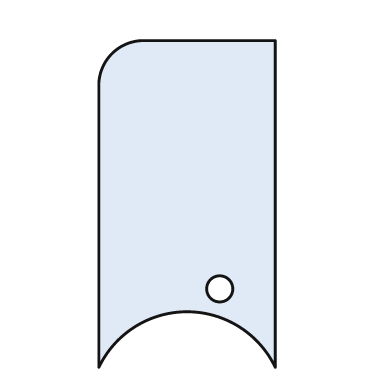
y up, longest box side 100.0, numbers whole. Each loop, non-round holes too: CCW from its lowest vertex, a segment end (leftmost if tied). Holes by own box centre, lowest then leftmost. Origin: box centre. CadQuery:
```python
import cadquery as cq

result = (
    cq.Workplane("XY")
    .moveTo(-27.0, -50.0)
    .threePointArc((0.0, -33.0), (27.0, -50.0))
    .lineTo(27.0, 50.0)
    .lineTo(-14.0, 50.0)
    .threePointArc((-23.0, 46.0), (-27.0, 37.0))
    .close()
    .moveTo(10.0, -26.0)
    .circle(4.0)
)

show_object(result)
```